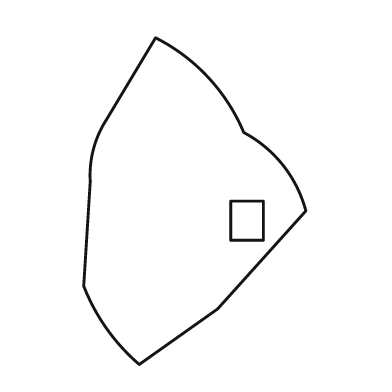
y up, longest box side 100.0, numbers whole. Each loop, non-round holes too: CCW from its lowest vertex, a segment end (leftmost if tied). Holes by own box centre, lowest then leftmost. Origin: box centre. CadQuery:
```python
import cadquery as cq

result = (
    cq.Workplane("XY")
    .moveTo(-17.0, -50.0)
    .lineTo(7.0, -33.0)
    .lineTo(34.0, -3.0)
    .threePointArc((27.0, 11.0), (15.0, 21.0))
    .threePointArc((4.0, 38.0), (-12.0, 50.0))
    .lineTo(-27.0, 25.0)
    .threePointArc((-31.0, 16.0), (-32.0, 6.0))
    .lineTo(-34.0, -26.0)
    .threePointArc((-27.0, -39.0), (-17.0, -50.0))
    .close()
    .moveTo(11.0, -12.0)
    .lineTo(21.0, -12.0)
    .lineTo(21.0, 0.0)
    .lineTo(11.0, 0.0)
    .close()
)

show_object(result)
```